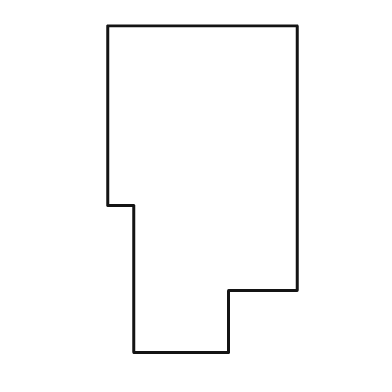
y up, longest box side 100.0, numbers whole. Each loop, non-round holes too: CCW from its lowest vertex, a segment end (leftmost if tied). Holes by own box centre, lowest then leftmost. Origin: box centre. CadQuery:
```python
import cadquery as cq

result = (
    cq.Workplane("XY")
    .moveTo(-21.0, -50.0)
    .lineTo(8.0, -50.0)
    .lineTo(8.0, -31.0)
    .lineTo(29.0, -31.0)
    .lineTo(29.0, 50.0)
    .lineTo(-29.0, 50.0)
    .lineTo(-29.0, -5.0)
    .lineTo(-21.0, -5.0)
    .close()
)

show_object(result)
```